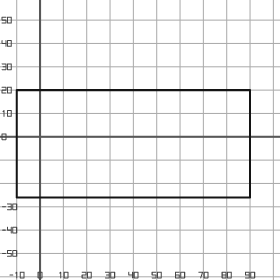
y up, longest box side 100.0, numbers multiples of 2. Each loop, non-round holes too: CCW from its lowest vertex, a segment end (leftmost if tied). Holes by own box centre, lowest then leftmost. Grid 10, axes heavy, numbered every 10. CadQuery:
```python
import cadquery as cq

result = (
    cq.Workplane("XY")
    .moveTo(-10.0, -26.0)
    .lineTo(90.0, -26.0)
    .lineTo(90.0, 20.0)
    .lineTo(-10.0, 20.0)
    .close()
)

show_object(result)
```